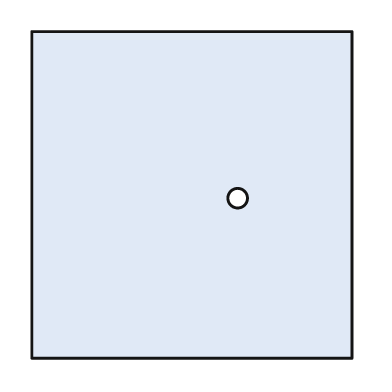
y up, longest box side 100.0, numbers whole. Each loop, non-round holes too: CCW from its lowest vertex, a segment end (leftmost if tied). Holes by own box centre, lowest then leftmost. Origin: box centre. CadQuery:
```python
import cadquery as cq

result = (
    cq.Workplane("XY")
    .moveTo(-49.0, -50.0)
    .lineTo(49.0, -50.0)
    .lineTo(49.0, 50.0)
    .lineTo(-49.0, 50.0)
    .close()
    .moveTo(14.0, -1.0)
    .circle(3.0)
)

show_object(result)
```